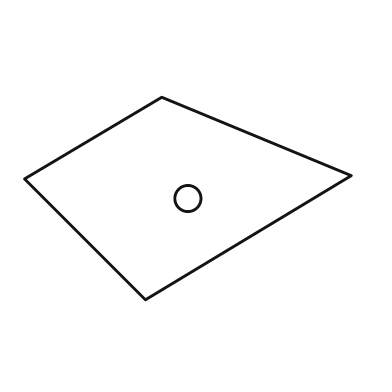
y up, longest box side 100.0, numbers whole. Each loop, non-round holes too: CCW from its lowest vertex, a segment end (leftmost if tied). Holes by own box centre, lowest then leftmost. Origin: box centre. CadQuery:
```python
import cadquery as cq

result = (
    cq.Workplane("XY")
    .moveTo(-13.0, -31.0)
    .lineTo(50.0, 7.0)
    .lineTo(-8.0, 31.0)
    .lineTo(-50.0, 6.0)
    .close()
    .moveTo(0.0, 0.0)
    .circle(4.0)
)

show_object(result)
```